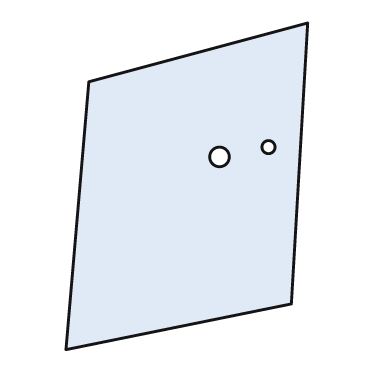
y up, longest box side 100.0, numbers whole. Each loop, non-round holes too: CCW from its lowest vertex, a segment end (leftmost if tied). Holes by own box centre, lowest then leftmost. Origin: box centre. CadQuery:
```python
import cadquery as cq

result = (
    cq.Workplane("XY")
    .moveTo(-37.0, -50.0)
    .lineTo(32.0, -36.0)
    .lineTo(37.0, 50.0)
    .lineTo(-30.0, 32.0)
    .close()
    .moveTo(10.0, 9.0)
    .circle(3.0)
    .moveTo(25.0, 12.0)
    .circle(2.0)
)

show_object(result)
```